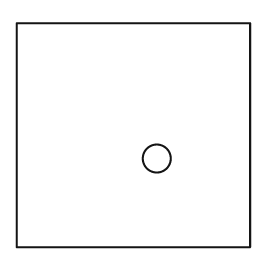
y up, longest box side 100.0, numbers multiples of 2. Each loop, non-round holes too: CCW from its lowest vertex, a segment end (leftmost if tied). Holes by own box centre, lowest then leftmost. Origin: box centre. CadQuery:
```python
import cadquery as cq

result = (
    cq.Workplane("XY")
    .moveTo(-50.0, -48.0)
    .lineTo(50.0, -48.0)
    .lineTo(50.0, 48.0)
    .lineTo(-50.0, 48.0)
    .close()
    .moveTo(10.0, -10.0)
    .circle(6.0)
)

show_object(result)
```